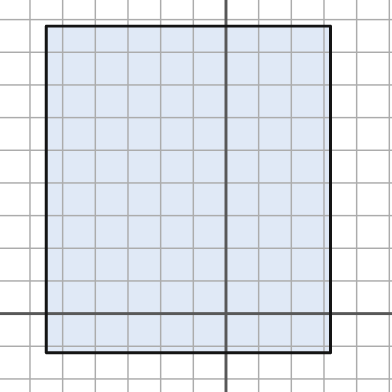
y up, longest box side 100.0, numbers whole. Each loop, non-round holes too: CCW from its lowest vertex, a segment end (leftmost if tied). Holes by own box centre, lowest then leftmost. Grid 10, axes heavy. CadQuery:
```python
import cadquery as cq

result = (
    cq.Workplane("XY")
    .moveTo(-55.0, -12.0)
    .lineTo(32.0, -12.0)
    .lineTo(32.0, 88.0)
    .lineTo(-55.0, 88.0)
    .close()
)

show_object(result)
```